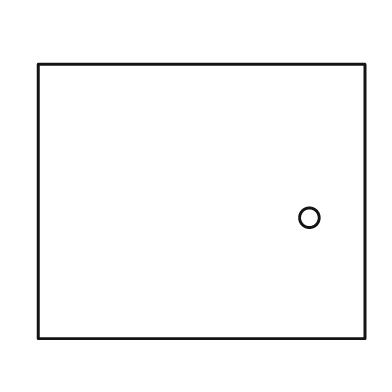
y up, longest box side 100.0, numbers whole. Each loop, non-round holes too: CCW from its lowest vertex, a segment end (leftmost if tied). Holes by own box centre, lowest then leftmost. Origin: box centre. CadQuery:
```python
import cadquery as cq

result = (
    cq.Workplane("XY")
    .moveTo(-50.0, -42.0)
    .lineTo(50.0, -42.0)
    .lineTo(50.0, 42.0)
    .lineTo(-50.0, 42.0)
    .close()
    .moveTo(33.0, -5.0)
    .circle(3.0)
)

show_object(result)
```